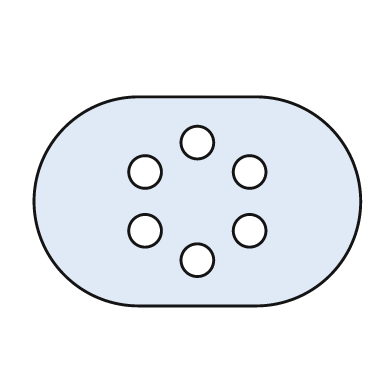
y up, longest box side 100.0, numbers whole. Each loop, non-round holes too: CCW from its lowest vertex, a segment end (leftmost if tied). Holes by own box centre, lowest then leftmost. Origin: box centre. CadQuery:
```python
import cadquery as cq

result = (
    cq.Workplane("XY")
    .moveTo(-18.0, -32.0)
    .lineTo(18.0, -32.0)
    .threePointArc((50.0, 0.0), (18.0, 32.0))
    .lineTo(-18.0, 32.0)
    .threePointArc((-50.0, 0.0), (-18.0, -32.0))
    .close()
    .moveTo(0.0, -18.0)
    .circle(5.0)
    .moveTo(-16.0, -9.0)
    .circle(5.0)
    .moveTo(16.0, -9.0)
    .circle(5.0)
    .moveTo(-16.0, 9.0)
    .circle(5.0)
    .moveTo(16.0, 9.0)
    .circle(5.0)
    .moveTo(0.0, 18.0)
    .circle(5.0)
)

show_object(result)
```